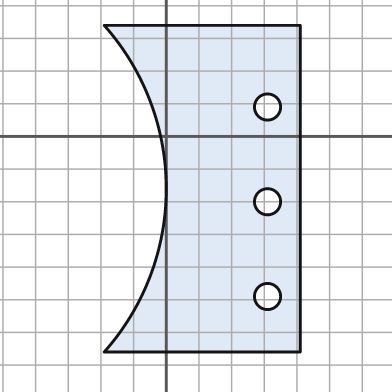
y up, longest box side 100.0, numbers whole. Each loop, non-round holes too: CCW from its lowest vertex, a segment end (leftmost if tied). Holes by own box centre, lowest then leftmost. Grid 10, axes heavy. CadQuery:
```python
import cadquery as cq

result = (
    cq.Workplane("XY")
    .moveTo(-19.0, -66.0)
    .lineTo(41.0, -66.0)
    .lineTo(41.0, 34.0)
    .lineTo(-19.0, 34.0)
    .threePointArc((0.0, -16.0), (-19.0, -66.0))
    .close()
    .moveTo(31.0, -49.0)
    .circle(4.0)
    .moveTo(31.0, -20.0)
    .circle(4.0)
    .moveTo(31.0, 9.0)
    .circle(4.0)
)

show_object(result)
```